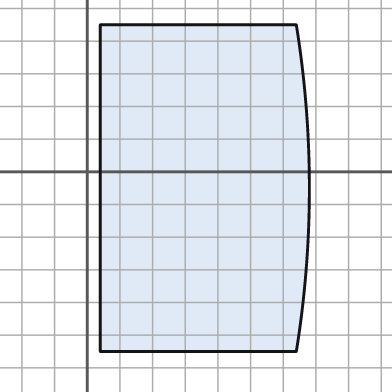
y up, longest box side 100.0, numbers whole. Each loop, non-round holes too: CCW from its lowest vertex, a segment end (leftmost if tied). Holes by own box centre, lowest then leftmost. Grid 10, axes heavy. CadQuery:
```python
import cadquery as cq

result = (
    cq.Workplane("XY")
    .moveTo(4.0, -55.0)
    .lineTo(64.0, -55.0)
    .threePointArc((68.0, -5.0), (64.0, 45.0))
    .lineTo(4.0, 45.0)
    .close()
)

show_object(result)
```